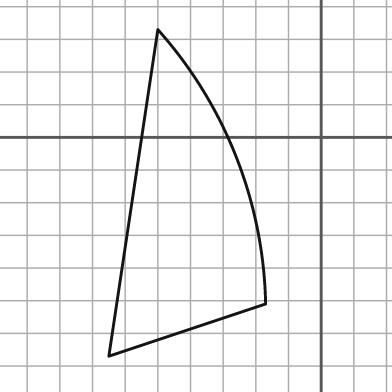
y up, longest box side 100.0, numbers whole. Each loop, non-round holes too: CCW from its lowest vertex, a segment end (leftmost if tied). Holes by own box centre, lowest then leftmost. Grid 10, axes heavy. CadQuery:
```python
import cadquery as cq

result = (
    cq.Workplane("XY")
    .moveTo(-65.0, -67.0)
    .lineTo(-17.0, -51.0)
    .threePointArc((-26.0, -6.0), (-50.0, 33.0))
    .close()
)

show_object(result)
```